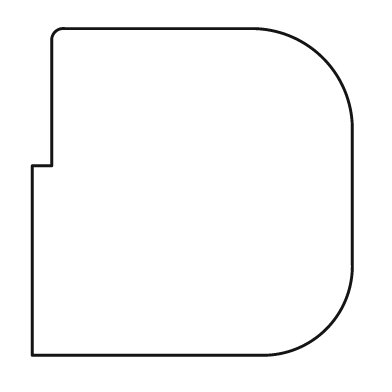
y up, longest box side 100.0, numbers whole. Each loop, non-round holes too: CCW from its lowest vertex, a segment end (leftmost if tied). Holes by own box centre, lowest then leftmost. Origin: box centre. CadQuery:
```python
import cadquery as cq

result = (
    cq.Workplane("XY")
    .moveTo(-49.0, -50.0)
    .lineTo(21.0, -50.0)
    .threePointArc((41.0, -42.0), (49.0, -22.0))
    .lineTo(49.0, 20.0)
    .threePointArc((40.0, 41.0), (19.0, 50.0))
    .lineTo(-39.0, 50.0)
    .threePointArc((-42.0, 49.0), (-43.0, 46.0))
    .lineTo(-43.0, 8.0)
    .lineTo(-49.0, 8.0)
    .close()
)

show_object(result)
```